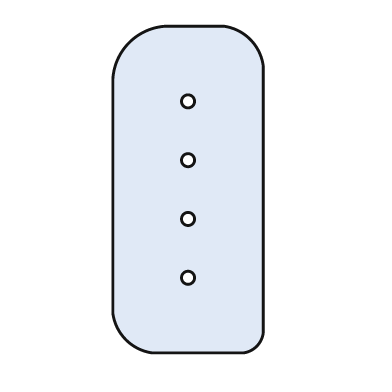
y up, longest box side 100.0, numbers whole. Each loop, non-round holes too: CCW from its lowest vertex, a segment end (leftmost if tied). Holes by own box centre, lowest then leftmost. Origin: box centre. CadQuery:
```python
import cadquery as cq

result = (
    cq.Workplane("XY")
    .moveTo(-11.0, -50.0)
    .lineTo(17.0, -50.0)
    .threePointArc((21.0, -48.0), (23.0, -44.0))
    .lineTo(23.0, 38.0)
    .threePointArc((19.0, 46.0), (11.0, 50.0))
    .lineTo(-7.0, 50.0)
    .threePointArc((-18.0, 45.0), (-23.0, 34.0))
    .lineTo(-23.0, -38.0)
    .threePointArc((-19.0, -46.0), (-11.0, -50.0))
    .close()
    .moveTo(0.0, -27.0)
    .circle(2.0)
    .moveTo(0.0, -9.0)
    .circle(2.0)
    .moveTo(0.0, 9.0)
    .circle(2.0)
    .moveTo(0.0, 27.0)
    .circle(2.0)
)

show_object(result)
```